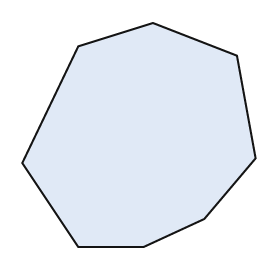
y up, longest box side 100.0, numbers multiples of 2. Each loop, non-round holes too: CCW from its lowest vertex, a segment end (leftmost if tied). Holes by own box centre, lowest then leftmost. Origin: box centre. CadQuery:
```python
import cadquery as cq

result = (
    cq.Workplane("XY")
    .moveTo(-26.0, -48.0)
    .lineTo(2.0, -48.0)
    .lineTo(28.0, -36.0)
    .lineTo(50.0, -10.0)
    .lineTo(42.0, 34.0)
    .lineTo(6.0, 48.0)
    .lineTo(-26.0, 38.0)
    .lineTo(-50.0, -12.0)
    .close()
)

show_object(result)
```